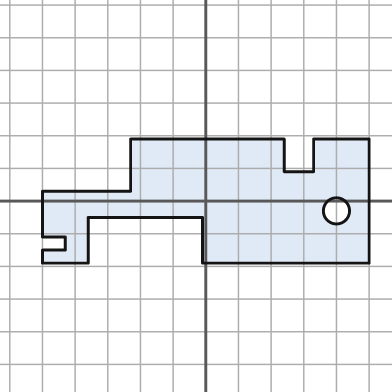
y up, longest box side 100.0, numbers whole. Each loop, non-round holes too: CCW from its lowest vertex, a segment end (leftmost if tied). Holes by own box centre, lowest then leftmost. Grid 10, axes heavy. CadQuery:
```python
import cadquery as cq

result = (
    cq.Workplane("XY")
    .moveTo(-50.0, -19.0)
    .lineTo(-36.0, -19.0)
    .lineTo(-36.0, -5.0)
    .lineTo(-1.0, -5.0)
    .lineTo(-1.0, -19.0)
    .lineTo(50.0, -19.0)
    .lineTo(50.0, 19.0)
    .lineTo(33.0, 19.0)
    .lineTo(33.0, 9.0)
    .lineTo(24.0, 9.0)
    .lineTo(24.0, 19.0)
    .lineTo(-23.0, 19.0)
    .lineTo(-23.0, 3.0)
    .lineTo(-50.0, 3.0)
    .lineTo(-50.0, -11.0)
    .lineTo(-43.0, -11.0)
    .lineTo(-43.0, -15.0)
    .lineTo(-50.0, -15.0)
    .close()
    .moveTo(40.0, -3.0)
    .circle(4.0)
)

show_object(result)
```